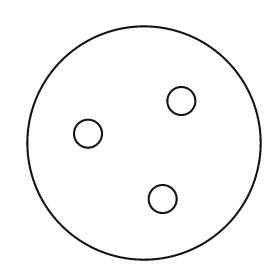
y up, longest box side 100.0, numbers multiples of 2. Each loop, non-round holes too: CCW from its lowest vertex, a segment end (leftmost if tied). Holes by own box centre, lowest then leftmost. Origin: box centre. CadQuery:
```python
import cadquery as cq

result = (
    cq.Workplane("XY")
    .moveTo(0.0, 0.0)
    .circle(50.0)
    .moveTo(8.0, -24.0)
    .circle(6.0)
    .moveTo(-24.0, 4.0)
    .circle(6.0)
    .moveTo(16.0, 18.0)
    .circle(6.0)
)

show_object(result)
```